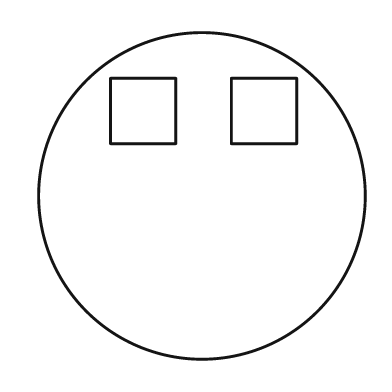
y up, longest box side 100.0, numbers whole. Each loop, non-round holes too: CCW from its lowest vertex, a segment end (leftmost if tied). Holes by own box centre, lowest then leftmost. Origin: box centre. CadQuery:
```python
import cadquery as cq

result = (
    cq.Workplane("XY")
    .moveTo(0.0, 0.0)
    .circle(50.0)
    .moveTo(-28.0, 16.0)
    .lineTo(-8.0, 16.0)
    .lineTo(-8.0, 36.0)
    .lineTo(-28.0, 36.0)
    .close()
    .moveTo(9.0, 16.0)
    .lineTo(29.0, 16.0)
    .lineTo(29.0, 36.0)
    .lineTo(9.0, 36.0)
    .close()
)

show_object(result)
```